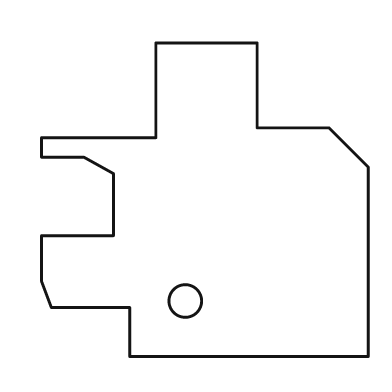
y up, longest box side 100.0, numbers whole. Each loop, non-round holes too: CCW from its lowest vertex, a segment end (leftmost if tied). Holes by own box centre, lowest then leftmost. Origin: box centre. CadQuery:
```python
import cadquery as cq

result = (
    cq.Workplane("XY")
    .moveTo(-23.0, -48.0)
    .lineTo(50.0, -48.0)
    .lineTo(50.0, 10.0)
    .lineTo(38.0, 22.0)
    .lineTo(16.0, 22.0)
    .lineTo(16.0, 48.0)
    .lineTo(-15.0, 48.0)
    .lineTo(-15.0, 19.0)
    .lineTo(-50.0, 19.0)
    .lineTo(-50.0, 13.0)
    .lineTo(-37.0, 13.0)
    .lineTo(-28.0, 8.0)
    .lineTo(-28.0, -11.0)
    .lineTo(-50.0, -11.0)
    .lineTo(-50.0, -25.0)
    .lineTo(-47.0, -33.0)
    .lineTo(-23.0, -33.0)
    .close()
    .moveTo(-6.0, -31.0)
    .circle(5.0)
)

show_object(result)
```